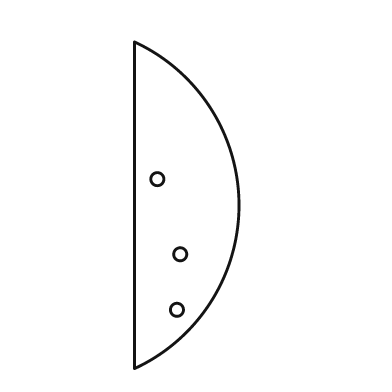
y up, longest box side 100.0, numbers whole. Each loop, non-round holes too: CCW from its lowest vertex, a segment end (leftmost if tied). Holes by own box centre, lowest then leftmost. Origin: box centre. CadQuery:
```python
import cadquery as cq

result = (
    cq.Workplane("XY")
    .moveTo(-16.0, -50.0)
    .threePointArc((16.0, 0.0), (-16.0, 50.0))
    .close()
    .moveTo(-3.0, -32.0)
    .circle(2.0)
    .moveTo(-2.0, -15.0)
    .circle(2.0)
    .moveTo(-9.0, 8.0)
    .circle(2.0)
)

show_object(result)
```